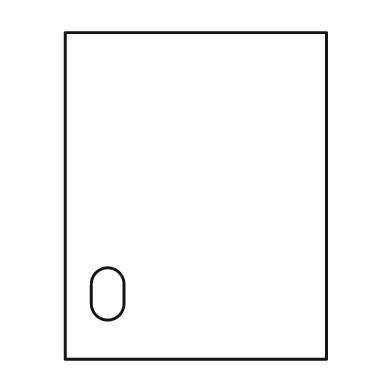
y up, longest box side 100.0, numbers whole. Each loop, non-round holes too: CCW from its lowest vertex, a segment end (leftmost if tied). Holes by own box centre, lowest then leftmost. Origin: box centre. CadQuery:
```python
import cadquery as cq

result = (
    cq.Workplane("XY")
    .moveTo(-40.0, -50.0)
    .lineTo(40.0, -50.0)
    .lineTo(40.0, 50.0)
    .lineTo(-40.0, 50.0)
    .close()
    .moveTo(-32.0, -33.0)
    .threePointArc((-27.0, -38.0), (-22.0, -33.0))
    .lineTo(-22.0, -27.0)
    .threePointArc((-27.0, -22.0), (-32.0, -27.0))
    .close()
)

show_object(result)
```